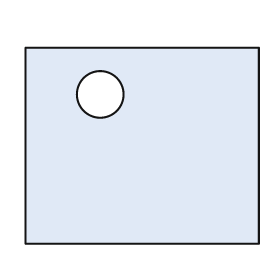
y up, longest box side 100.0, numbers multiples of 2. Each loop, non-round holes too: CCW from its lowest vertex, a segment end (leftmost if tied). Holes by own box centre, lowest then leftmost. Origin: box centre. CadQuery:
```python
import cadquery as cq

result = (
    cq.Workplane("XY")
    .moveTo(-50.0, -42.0)
    .lineTo(50.0, -42.0)
    .lineTo(50.0, 42.0)
    .lineTo(-50.0, 42.0)
    .close()
    .moveTo(-18.0, 22.0)
    .circle(10.0)
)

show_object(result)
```